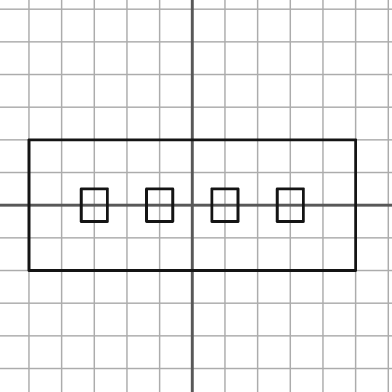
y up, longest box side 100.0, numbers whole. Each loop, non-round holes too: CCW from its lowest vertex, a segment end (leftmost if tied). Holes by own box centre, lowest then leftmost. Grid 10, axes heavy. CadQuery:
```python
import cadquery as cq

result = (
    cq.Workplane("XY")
    .moveTo(-50.0, -20.0)
    .lineTo(50.0, -20.0)
    .lineTo(50.0, 20.0)
    .lineTo(-50.0, 20.0)
    .close()
    .moveTo(-34.0, -5.0)
    .lineTo(-26.0, -5.0)
    .lineTo(-26.0, 5.0)
    .lineTo(-34.0, 5.0)
    .close()
    .moveTo(-14.0, -5.0)
    .lineTo(-6.0, -5.0)
    .lineTo(-6.0, 5.0)
    .lineTo(-14.0, 5.0)
    .close()
    .moveTo(6.0, -5.0)
    .lineTo(14.0, -5.0)
    .lineTo(14.0, 5.0)
    .lineTo(6.0, 5.0)
    .close()
    .moveTo(26.0, -5.0)
    .lineTo(34.0, -5.0)
    .lineTo(34.0, 5.0)
    .lineTo(26.0, 5.0)
    .close()
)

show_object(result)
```